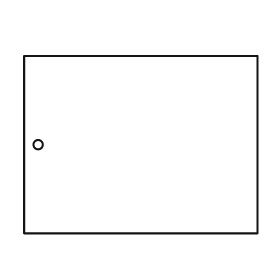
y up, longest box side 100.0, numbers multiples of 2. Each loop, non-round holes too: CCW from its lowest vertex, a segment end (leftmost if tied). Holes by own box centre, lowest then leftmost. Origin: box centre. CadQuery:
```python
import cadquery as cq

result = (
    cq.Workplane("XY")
    .moveTo(-50.0, -38.0)
    .lineTo(50.0, -38.0)
    .lineTo(50.0, 38.0)
    .lineTo(-50.0, 38.0)
    .close()
    .moveTo(-44.0, 0.0)
    .circle(2.0)
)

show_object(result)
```